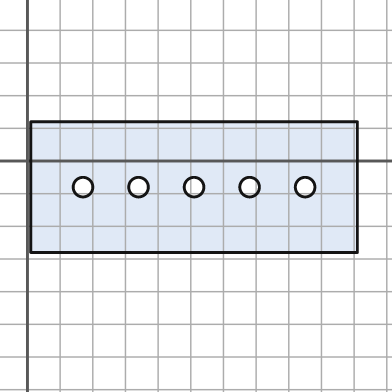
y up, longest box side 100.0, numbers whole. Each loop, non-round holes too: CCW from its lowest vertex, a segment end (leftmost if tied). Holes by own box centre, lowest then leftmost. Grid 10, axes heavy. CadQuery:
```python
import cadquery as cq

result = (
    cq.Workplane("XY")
    .moveTo(1.0, -28.0)
    .lineTo(101.0, -28.0)
    .lineTo(101.0, 12.0)
    .lineTo(1.0, 12.0)
    .close()
    .moveTo(17.0, -8.0)
    .circle(3.0)
    .moveTo(34.0, -8.0)
    .circle(3.0)
    .moveTo(51.0, -8.0)
    .circle(3.0)
    .moveTo(68.0, -8.0)
    .circle(3.0)
    .moveTo(85.0, -8.0)
    .circle(3.0)
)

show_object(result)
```